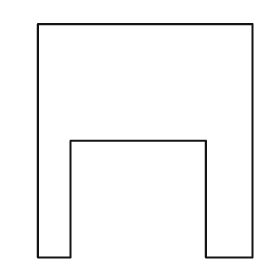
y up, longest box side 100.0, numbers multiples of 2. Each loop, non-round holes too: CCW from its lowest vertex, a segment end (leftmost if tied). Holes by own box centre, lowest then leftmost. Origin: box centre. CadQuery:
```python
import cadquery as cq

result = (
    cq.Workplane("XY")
    .moveTo(-46.0, -50.0)
    .lineTo(-32.0, -50.0)
    .lineTo(-32.0, 0.0)
    .lineTo(26.0, 0.0)
    .lineTo(26.0, -50.0)
    .lineTo(46.0, -50.0)
    .lineTo(46.0, 50.0)
    .lineTo(-46.0, 50.0)
    .close()
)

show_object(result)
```